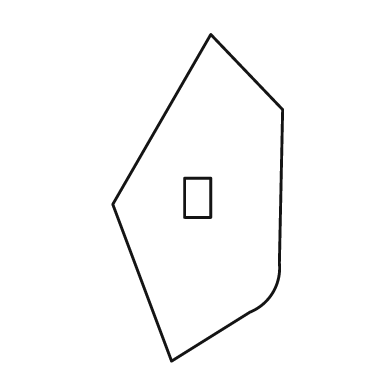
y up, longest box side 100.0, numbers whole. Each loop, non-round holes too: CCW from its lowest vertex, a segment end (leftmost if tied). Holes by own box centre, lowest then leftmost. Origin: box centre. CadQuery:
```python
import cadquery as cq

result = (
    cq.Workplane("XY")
    .moveTo(-8.0, -50.0)
    .lineTo(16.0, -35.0)
    .threePointArc((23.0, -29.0), (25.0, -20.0))
    .lineTo(26.0, 27.0)
    .lineTo(4.0, 50.0)
    .lineTo(-26.0, -2.0)
    .close()
    .moveTo(-4.0, -6.0)
    .lineTo(4.0, -6.0)
    .lineTo(4.0, 6.0)
    .lineTo(-4.0, 6.0)
    .close()
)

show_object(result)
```